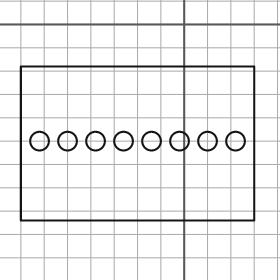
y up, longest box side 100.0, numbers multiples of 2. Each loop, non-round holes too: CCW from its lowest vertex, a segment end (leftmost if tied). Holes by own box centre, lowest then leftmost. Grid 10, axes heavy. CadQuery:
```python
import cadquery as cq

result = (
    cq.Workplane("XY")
    .moveTo(-70.0, -84.0)
    .lineTo(30.0, -84.0)
    .lineTo(30.0, -18.0)
    .lineTo(-70.0, -18.0)
    .close()
    .moveTo(-62.0, -50.0)
    .circle(4.0)
    .moveTo(-50.0, -50.0)
    .circle(4.0)
    .moveTo(-38.0, -50.0)
    .circle(4.0)
    .moveTo(-26.0, -50.0)
    .circle(4.0)
    .moveTo(-14.0, -50.0)
    .circle(4.0)
    .moveTo(-2.0, -50.0)
    .circle(4.0)
    .moveTo(10.0, -50.0)
    .circle(4.0)
    .moveTo(22.0, -50.0)
    .circle(4.0)
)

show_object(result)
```